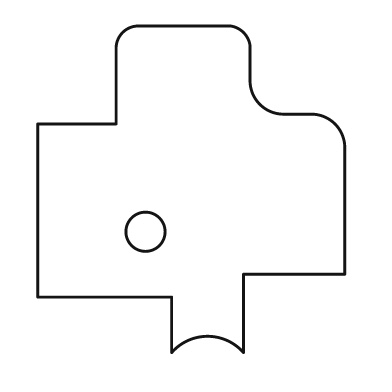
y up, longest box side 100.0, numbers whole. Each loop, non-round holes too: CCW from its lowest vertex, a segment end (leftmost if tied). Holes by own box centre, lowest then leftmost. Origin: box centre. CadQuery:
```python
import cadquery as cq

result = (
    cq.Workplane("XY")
    .moveTo(-6.0, -50.0)
    .threePointArc((5.0, -45.0), (16.0, -50.0))
    .lineTo(16.0, -26.0)
    .lineTo(47.0, -26.0)
    .lineTo(47.0, 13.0)
    .threePointArc((44.0, 20.0), (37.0, 23.0))
    .lineTo(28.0, 23.0)
    .threePointArc((21.0, 26.0), (18.0, 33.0))
    .lineTo(18.0, 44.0)
    .threePointArc((16.0, 48.0), (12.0, 50.0))
    .lineTo(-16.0, 50.0)
    .threePointArc((-21.0, 48.0), (-23.0, 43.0))
    .lineTo(-23.0, 20.0)
    .lineTo(-47.0, 20.0)
    .lineTo(-47.0, -33.0)
    .lineTo(-6.0, -33.0)
    .close()
    .moveTo(-14.0, -13.0)
    .circle(6.0)
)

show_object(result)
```